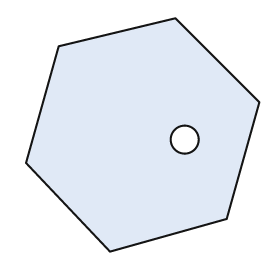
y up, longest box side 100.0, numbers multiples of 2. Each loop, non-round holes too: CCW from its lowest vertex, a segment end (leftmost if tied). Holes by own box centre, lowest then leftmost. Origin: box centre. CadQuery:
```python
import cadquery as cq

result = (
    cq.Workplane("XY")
    .moveTo(-14.0, -50.0)
    .lineTo(36.0, -36.0)
    .lineTo(50.0, 14.0)
    .lineTo(14.0, 50.0)
    .lineTo(-36.0, 38.0)
    .lineTo(-50.0, -12.0)
    .close()
    .moveTo(18.0, -2.0)
    .circle(6.0)
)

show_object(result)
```